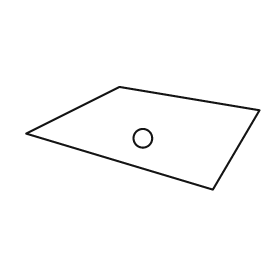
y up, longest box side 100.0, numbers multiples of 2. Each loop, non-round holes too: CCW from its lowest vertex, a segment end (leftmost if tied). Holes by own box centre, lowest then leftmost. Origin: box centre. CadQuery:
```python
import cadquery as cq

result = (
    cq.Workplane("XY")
    .moveTo(30.0, -22.0)
    .lineTo(50.0, 12.0)
    .lineTo(-10.0, 22.0)
    .lineTo(-50.0, 2.0)
    .close()
    .moveTo(0.0, 0.0)
    .circle(4.0)
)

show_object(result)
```